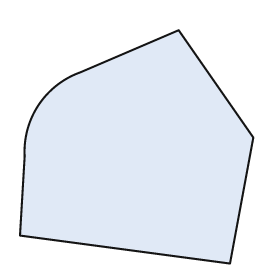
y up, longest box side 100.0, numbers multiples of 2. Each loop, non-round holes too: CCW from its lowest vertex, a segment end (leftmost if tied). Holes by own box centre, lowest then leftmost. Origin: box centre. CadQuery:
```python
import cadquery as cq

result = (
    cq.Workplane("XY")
    .moveTo(40.0, -50.0)
    .lineTo(50.0, 4.0)
    .lineTo(18.0, 50.0)
    .lineTo(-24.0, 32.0)
    .threePointArc((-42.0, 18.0), (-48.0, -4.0))
    .lineTo(-50.0, -38.0)
    .close()
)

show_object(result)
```